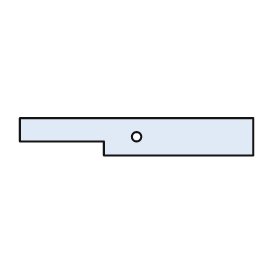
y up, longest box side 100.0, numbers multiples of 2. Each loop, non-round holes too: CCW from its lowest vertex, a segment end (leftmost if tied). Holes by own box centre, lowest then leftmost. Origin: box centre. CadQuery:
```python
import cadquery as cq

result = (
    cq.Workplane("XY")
    .moveTo(-14.0, -8.0)
    .lineTo(50.0, -8.0)
    .lineTo(50.0, 8.0)
    .lineTo(-50.0, 8.0)
    .lineTo(-50.0, -2.0)
    .lineTo(-14.0, -2.0)
    .close()
    .moveTo(0.0, 0.0)
    .circle(2.0)
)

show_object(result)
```